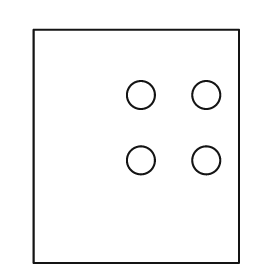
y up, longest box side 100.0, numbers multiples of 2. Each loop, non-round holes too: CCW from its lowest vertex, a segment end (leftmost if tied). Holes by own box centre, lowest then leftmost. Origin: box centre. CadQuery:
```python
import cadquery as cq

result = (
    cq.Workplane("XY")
    .moveTo(-44.0, -50.0)
    .lineTo(44.0, -50.0)
    .lineTo(44.0, 50.0)
    .lineTo(-44.0, 50.0)
    .close()
    .moveTo(2.0, -6.0)
    .circle(6.0)
    .moveTo(30.0, -6.0)
    .circle(6.0)
    .moveTo(2.0, 22.0)
    .circle(6.0)
    .moveTo(30.0, 22.0)
    .circle(6.0)
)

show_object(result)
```